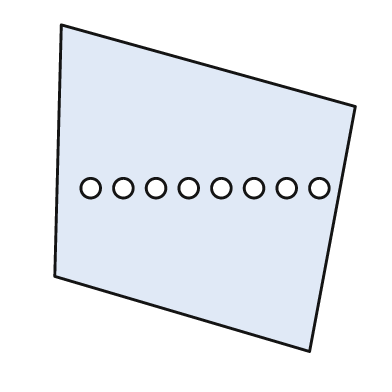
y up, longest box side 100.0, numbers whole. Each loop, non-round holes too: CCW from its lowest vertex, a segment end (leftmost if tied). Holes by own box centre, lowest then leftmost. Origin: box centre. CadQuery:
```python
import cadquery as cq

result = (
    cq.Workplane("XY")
    .moveTo(32.0, -50.0)
    .lineTo(46.0, 25.0)
    .lineTo(-44.0, 50.0)
    .lineTo(-46.0, -27.0)
    .close()
    .moveTo(-35.0, 0.0)
    .circle(3.0)
    .moveTo(-25.0, 0.0)
    .circle(3.0)
    .moveTo(-15.0, 0.0)
    .circle(3.0)
    .moveTo(-5.0, 0.0)
    .circle(3.0)
    .moveTo(5.0, 0.0)
    .circle(3.0)
    .moveTo(15.0, 0.0)
    .circle(3.0)
    .moveTo(25.0, 0.0)
    .circle(3.0)
    .moveTo(35.0, 0.0)
    .circle(3.0)
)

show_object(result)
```